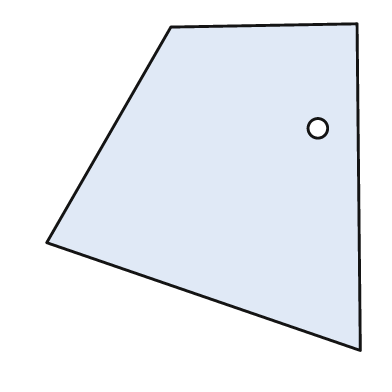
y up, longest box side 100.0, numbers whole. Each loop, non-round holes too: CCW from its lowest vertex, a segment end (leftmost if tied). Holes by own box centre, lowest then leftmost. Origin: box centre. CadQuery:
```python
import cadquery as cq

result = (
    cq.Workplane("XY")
    .moveTo(48.0, -50.0)
    .lineTo(47.0, 50.0)
    .lineTo(-10.0, 49.0)
    .lineTo(-48.0, -17.0)
    .close()
    .moveTo(35.0, 18.0)
    .circle(3.0)
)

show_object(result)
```